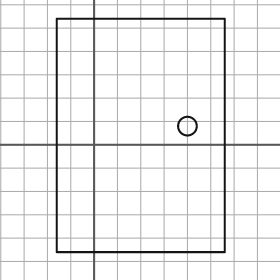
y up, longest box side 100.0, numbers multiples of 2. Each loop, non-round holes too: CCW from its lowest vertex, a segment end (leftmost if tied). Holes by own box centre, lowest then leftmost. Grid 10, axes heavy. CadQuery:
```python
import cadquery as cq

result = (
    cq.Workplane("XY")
    .moveTo(-16.0, -46.0)
    .lineTo(56.0, -46.0)
    .lineTo(56.0, 54.0)
    .lineTo(-16.0, 54.0)
    .close()
    .moveTo(40.0, 8.0)
    .circle(4.0)
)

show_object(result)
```